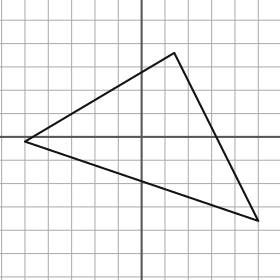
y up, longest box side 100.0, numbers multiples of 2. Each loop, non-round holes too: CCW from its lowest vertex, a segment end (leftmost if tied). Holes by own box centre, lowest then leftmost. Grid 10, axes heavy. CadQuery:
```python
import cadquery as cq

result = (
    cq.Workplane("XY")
    .moveTo(50.0, -36.0)
    .lineTo(14.0, 36.0)
    .lineTo(-50.0, -2.0)
    .close()
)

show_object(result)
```